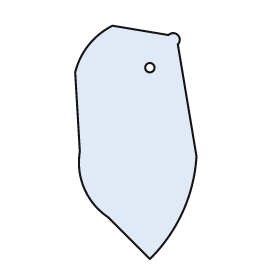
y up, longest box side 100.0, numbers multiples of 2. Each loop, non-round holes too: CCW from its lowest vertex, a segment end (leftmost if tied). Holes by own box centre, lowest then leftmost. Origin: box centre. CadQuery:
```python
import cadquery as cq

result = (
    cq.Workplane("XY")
    .moveTo(6.0, -50.0)
    .threePointArc((20.0, -30.0), (26.0, -6.0))
    .lineTo(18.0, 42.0)
    .threePointArc((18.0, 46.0), (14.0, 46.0))
    .lineTo(-10.0, 50.0)
    .threePointArc((-20.0, 42.0), (-26.0, 30.0))
    .lineTo(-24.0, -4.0)
    .threePointArc((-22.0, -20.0), (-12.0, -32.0))
    .close()
    .moveTo(6.0, 32.0)
    .circle(2.0)
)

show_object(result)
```